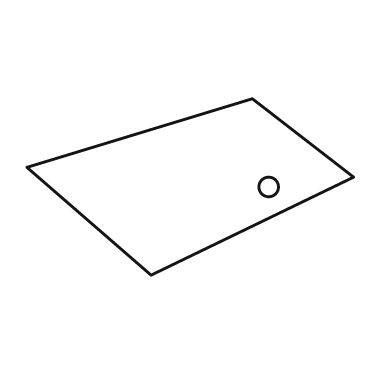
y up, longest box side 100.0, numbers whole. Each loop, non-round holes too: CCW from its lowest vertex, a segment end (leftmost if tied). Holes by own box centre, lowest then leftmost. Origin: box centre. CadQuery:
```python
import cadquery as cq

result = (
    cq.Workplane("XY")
    .moveTo(-12.0, -27.0)
    .lineTo(50.0, 3.0)
    .lineTo(19.0, 27.0)
    .lineTo(-50.0, 6.0)
    .close()
    .moveTo(24.0, 0.0)
    .circle(3.0)
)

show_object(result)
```